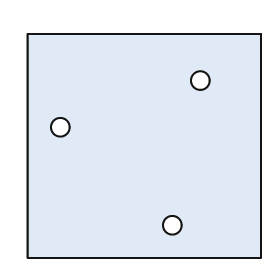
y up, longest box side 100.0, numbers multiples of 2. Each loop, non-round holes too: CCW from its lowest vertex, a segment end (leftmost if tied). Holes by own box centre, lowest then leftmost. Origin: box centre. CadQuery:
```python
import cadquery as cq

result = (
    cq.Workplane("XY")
    .moveTo(-50.0, -48.0)
    .lineTo(50.0, -48.0)
    .lineTo(50.0, 48.0)
    .lineTo(-50.0, 48.0)
    .close()
    .moveTo(12.0, -34.0)
    .circle(4.0)
    .moveTo(-36.0, 8.0)
    .circle(4.0)
    .moveTo(24.0, 28.0)
    .circle(4.0)
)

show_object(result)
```